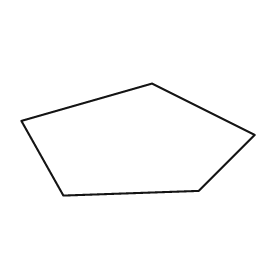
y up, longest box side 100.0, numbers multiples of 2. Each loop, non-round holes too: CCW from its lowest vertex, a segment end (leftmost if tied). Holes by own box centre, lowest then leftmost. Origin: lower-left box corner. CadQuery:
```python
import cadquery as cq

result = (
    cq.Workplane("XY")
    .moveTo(18.0, 0.0)
    .lineTo(76.0, 2.0)
    .lineTo(100.0, 26.0)
    .lineTo(56.0, 48.0)
    .lineTo(0.0, 32.0)
    .close()
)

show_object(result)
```